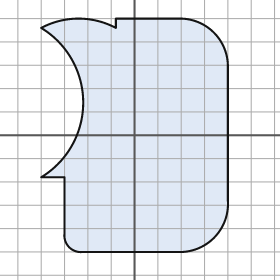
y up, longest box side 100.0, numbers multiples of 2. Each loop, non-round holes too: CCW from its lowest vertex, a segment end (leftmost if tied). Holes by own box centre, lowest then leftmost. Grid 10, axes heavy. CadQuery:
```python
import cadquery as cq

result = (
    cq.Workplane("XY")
    .moveTo(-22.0, -50.0)
    .lineTo(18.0, -50.0)
    .threePointArc((34.0, -44.0), (40.0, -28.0))
    .lineTo(40.0, 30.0)
    .threePointArc((34.0, 44.0), (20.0, 50.0))
    .lineTo(-8.0, 50.0)
    .lineTo(-8.0, 46.0)
    .threePointArc((-24.0, 50.0), (-40.0, 46.0))
    .threePointArc((-22.0, 14.0), (-40.0, -18.0))
    .lineTo(-30.0, -18.0)
    .lineTo(-30.0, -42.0)
    .threePointArc((-28.0, -48.0), (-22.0, -50.0))
    .close()
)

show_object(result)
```